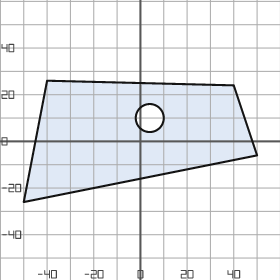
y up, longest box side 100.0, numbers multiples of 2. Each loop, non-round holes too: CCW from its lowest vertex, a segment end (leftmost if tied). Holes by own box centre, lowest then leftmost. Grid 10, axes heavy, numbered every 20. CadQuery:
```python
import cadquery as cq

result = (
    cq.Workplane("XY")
    .moveTo(-50.0, -26.0)
    .lineTo(50.0, -6.0)
    .lineTo(40.0, 24.0)
    .lineTo(-40.0, 26.0)
    .close()
    .moveTo(4.0, 10.0)
    .circle(6.0)
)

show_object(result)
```